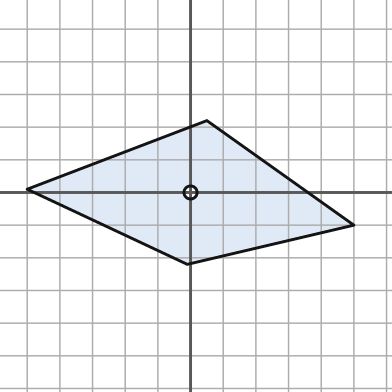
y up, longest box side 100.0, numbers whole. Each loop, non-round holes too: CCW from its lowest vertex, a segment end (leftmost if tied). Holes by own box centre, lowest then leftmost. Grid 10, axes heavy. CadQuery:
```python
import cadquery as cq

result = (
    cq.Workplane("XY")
    .moveTo(-1.0, -22.0)
    .lineTo(50.0, -10.0)
    .lineTo(5.0, 22.0)
    .lineTo(-50.0, 1.0)
    .close()
    .moveTo(0.0, 0.0)
    .circle(2.0)
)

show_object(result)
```